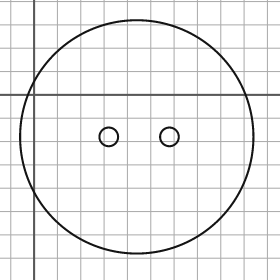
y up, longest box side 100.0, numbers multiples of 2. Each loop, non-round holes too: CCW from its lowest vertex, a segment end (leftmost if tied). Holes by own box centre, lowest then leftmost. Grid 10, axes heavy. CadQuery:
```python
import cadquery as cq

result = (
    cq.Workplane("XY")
    .moveTo(44.0, -18.0)
    .circle(50.0)
    .moveTo(32.0, -18.0)
    .circle(4.0)
    .moveTo(58.0, -18.0)
    .circle(4.0)
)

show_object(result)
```